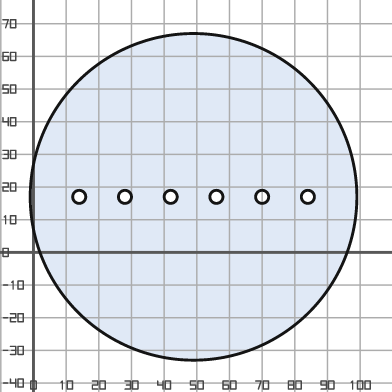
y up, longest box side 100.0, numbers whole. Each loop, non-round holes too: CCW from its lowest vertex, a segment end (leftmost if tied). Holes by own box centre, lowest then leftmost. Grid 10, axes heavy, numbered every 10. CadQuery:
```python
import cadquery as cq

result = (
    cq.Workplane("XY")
    .moveTo(49.0, 17.0)
    .circle(50.0)
    .moveTo(14.0, 17.0)
    .circle(2.0)
    .moveTo(28.0, 17.0)
    .circle(2.0)
    .moveTo(42.0, 17.0)
    .circle(2.0)
    .moveTo(56.0, 17.0)
    .circle(2.0)
    .moveTo(70.0, 17.0)
    .circle(2.0)
    .moveTo(84.0, 17.0)
    .circle(2.0)
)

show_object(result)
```